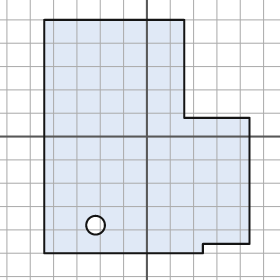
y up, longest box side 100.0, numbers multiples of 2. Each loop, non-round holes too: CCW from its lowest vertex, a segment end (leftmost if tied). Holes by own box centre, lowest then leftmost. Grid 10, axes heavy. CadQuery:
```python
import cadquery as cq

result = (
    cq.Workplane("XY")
    .moveTo(-44.0, -50.0)
    .lineTo(24.0, -50.0)
    .lineTo(24.0, -46.0)
    .lineTo(44.0, -46.0)
    .lineTo(44.0, 8.0)
    .lineTo(16.0, 8.0)
    .lineTo(16.0, 50.0)
    .lineTo(-44.0, 50.0)
    .close()
    .moveTo(-22.0, -38.0)
    .circle(4.0)
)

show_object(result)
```